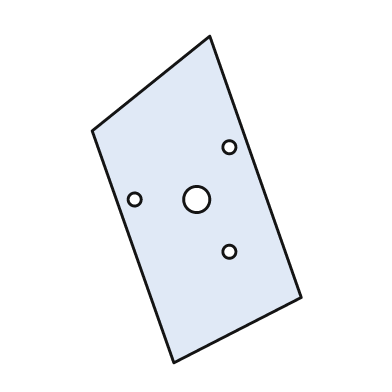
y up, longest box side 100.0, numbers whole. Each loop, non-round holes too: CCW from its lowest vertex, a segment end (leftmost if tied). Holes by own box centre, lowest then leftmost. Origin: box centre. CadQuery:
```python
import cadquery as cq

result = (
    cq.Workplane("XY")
    .moveTo(-7.0, -50.0)
    .lineTo(32.0, -30.0)
    .lineTo(4.0, 50.0)
    .lineTo(-32.0, 21.0)
    .close()
    .moveTo(10.0, -16.0)
    .circle(2.0)
    .moveTo(-19.0, 0.0)
    .circle(2.0)
    .moveTo(0.0, 0.0)
    .circle(4.0)
    .moveTo(10.0, 16.0)
    .circle(2.0)
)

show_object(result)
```